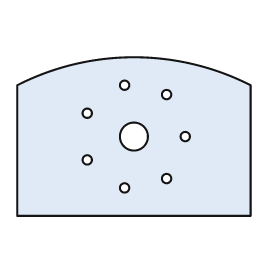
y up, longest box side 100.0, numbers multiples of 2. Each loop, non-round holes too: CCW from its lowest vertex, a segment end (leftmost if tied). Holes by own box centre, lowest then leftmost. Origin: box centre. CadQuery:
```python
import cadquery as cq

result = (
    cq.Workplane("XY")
    .moveTo(-50.0, -34.0)
    .lineTo(50.0, -34.0)
    .lineTo(50.0, 22.0)
    .threePointArc((0.0, 34.0), (-50.0, 22.0))
    .close()
    .moveTo(-4.0, -22.0)
    .circle(2.0)
    .moveTo(14.0, -18.0)
    .circle(2.0)
    .moveTo(-20.0, -10.0)
    .circle(2.0)
    .moveTo(0.0, 0.0)
    .circle(6.0)
    .moveTo(22.0, 0.0)
    .circle(2.0)
    .moveTo(-20.0, 10.0)
    .circle(2.0)
    .moveTo(14.0, 18.0)
    .circle(2.0)
    .moveTo(-4.0, 22.0)
    .circle(2.0)
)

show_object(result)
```